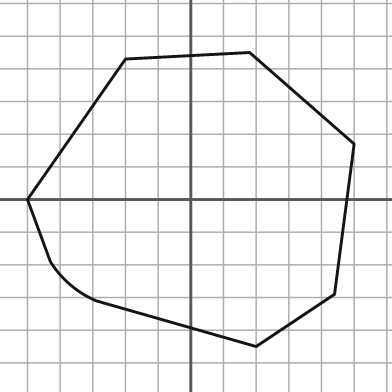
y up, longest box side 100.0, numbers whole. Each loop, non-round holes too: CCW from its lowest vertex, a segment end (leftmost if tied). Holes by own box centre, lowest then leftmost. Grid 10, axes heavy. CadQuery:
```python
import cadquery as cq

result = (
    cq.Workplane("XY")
    .moveTo(20.0, -45.0)
    .lineTo(44.0, -29.0)
    .lineTo(50.0, 17.0)
    .lineTo(18.0, 45.0)
    .lineTo(-20.0, 43.0)
    .lineTo(-50.0, 0.0)
    .lineTo(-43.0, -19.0)
    .threePointArc((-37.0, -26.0), (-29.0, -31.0))
    .close()
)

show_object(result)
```